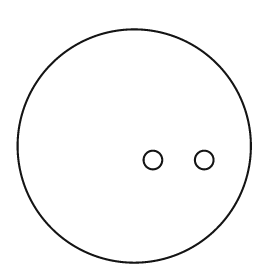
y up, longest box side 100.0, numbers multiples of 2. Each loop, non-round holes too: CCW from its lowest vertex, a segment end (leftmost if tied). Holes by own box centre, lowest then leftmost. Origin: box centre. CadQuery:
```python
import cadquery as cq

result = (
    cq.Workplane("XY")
    .moveTo(0.0, 0.0)
    .circle(50.0)
    .moveTo(8.0, -6.0)
    .circle(4.0)
    .moveTo(30.0, -6.0)
    .circle(4.0)
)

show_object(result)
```